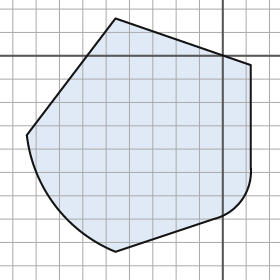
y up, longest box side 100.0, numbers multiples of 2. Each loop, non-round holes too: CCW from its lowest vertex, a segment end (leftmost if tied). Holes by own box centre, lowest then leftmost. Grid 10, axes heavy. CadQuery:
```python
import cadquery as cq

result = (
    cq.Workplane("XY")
    .moveTo(-46.0, -84.0)
    .lineTo(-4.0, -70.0)
    .threePointArc((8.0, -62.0), (12.0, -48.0))
    .lineTo(12.0, -4.0)
    .lineTo(-46.0, 16.0)
    .lineTo(-84.0, -34.0)
    .threePointArc((-72.0, -64.0), (-46.0, -84.0))
    .close()
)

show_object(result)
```